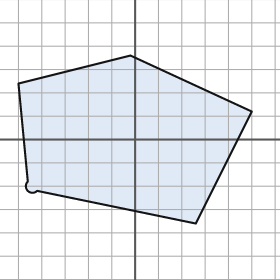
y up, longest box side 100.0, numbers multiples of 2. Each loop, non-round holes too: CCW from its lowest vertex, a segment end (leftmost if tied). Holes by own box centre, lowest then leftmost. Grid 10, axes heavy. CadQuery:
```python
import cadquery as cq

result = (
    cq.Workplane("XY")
    .moveTo(26.0, -36.0)
    .lineTo(50.0, 12.0)
    .lineTo(-2.0, 36.0)
    .lineTo(-50.0, 24.0)
    .lineTo(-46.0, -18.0)
    .threePointArc((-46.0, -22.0), (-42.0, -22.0))
    .close()
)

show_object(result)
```